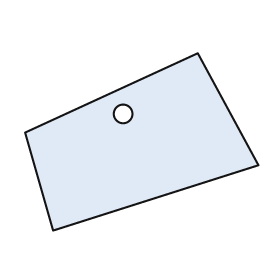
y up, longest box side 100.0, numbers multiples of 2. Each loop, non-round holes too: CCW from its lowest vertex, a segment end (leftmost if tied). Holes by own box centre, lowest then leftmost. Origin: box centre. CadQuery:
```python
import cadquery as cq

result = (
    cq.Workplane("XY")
    .moveTo(-38.0, -38.0)
    .lineTo(50.0, -10.0)
    .lineTo(24.0, 38.0)
    .lineTo(-50.0, 4.0)
    .close()
    .moveTo(-8.0, 12.0)
    .circle(4.0)
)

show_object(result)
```